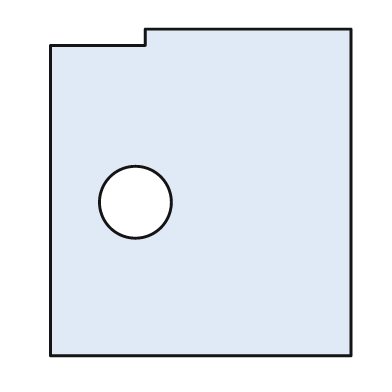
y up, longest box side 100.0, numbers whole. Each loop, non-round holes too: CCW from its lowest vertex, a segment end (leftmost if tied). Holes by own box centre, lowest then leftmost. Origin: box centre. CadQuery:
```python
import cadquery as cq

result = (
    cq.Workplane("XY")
    .moveTo(-46.0, -50.0)
    .lineTo(46.0, -50.0)
    .lineTo(46.0, 50.0)
    .lineTo(-17.0, 50.0)
    .lineTo(-17.0, 45.0)
    .lineTo(-46.0, 45.0)
    .close()
    .moveTo(-20.0, -3.0)
    .circle(11.0)
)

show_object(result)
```